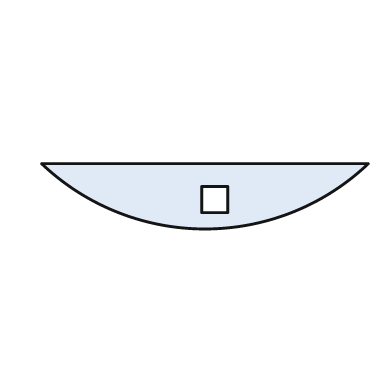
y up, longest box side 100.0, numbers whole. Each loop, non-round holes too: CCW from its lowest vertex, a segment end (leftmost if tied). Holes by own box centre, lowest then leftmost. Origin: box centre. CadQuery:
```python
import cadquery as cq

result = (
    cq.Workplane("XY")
    .moveTo(-50.0, 10.0)
    .threePointArc((0.0, -10.0), (50.0, 10.0))
    .close()
    .moveTo(-1.0, -5.0)
    .lineTo(7.0, -5.0)
    .lineTo(7.0, 3.0)
    .lineTo(-1.0, 3.0)
    .close()
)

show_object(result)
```